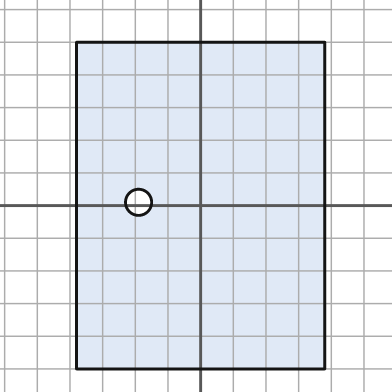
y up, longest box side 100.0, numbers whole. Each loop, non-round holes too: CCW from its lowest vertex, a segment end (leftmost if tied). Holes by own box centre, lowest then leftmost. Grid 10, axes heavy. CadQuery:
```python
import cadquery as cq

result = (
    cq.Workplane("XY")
    .moveTo(-38.0, -50.0)
    .lineTo(38.0, -50.0)
    .lineTo(38.0, 50.0)
    .lineTo(-38.0, 50.0)
    .close()
    .moveTo(-19.0, 1.0)
    .circle(4.0)
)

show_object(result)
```